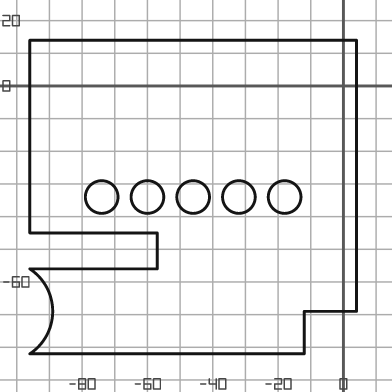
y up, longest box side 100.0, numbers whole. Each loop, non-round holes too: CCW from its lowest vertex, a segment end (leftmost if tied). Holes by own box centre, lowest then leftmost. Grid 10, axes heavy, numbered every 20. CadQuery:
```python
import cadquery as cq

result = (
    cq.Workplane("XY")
    .moveTo(-96.0, -82.0)
    .lineTo(-12.0, -82.0)
    .lineTo(-12.0, -69.0)
    .lineTo(4.0, -69.0)
    .lineTo(4.0, 14.0)
    .lineTo(-96.0, 14.0)
    .lineTo(-96.0, -45.0)
    .lineTo(-57.0, -45.0)
    .lineTo(-57.0, -56.0)
    .lineTo(-96.0, -56.0)
    .threePointArc((-89.0, -69.0), (-96.0, -82.0))
    .close()
    .moveTo(-74.0, -34.0)
    .circle(5.0)
    .moveTo(-60.0, -34.0)
    .circle(5.0)
    .moveTo(-46.0, -34.0)
    .circle(5.0)
    .moveTo(-32.0, -34.0)
    .circle(5.0)
    .moveTo(-18.0, -34.0)
    .circle(5.0)
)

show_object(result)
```